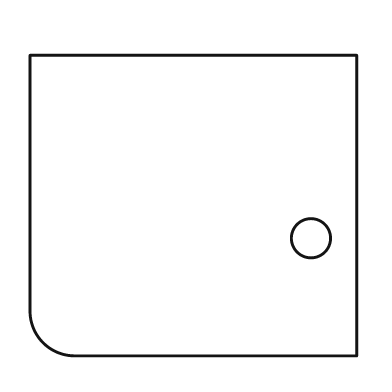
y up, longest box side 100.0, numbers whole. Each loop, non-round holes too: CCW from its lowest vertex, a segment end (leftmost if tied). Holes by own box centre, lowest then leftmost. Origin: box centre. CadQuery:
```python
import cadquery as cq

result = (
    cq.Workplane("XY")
    .moveTo(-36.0, -46.0)
    .lineTo(50.0, -46.0)
    .lineTo(50.0, 46.0)
    .lineTo(-50.0, 46.0)
    .lineTo(-50.0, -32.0)
    .threePointArc((-46.0, -42.0), (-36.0, -46.0))
    .close()
    .moveTo(36.0, -10.0)
    .circle(6.0)
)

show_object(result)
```